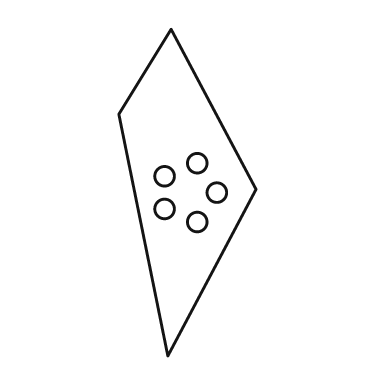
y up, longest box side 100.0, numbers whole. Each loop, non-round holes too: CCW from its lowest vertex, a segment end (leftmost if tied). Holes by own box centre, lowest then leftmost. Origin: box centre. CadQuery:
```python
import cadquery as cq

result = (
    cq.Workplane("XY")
    .moveTo(-6.0, -50.0)
    .lineTo(21.0, 1.0)
    .lineTo(-5.0, 50.0)
    .lineTo(-21.0, 24.0)
    .close()
    .moveTo(3.0, -9.0)
    .circle(3.0)
    .moveTo(-7.0, -5.0)
    .circle(3.0)
    .moveTo(9.0, 0.0)
    .circle(3.0)
    .moveTo(-7.0, 5.0)
    .circle(3.0)
    .moveTo(3.0, 9.0)
    .circle(3.0)
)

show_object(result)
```